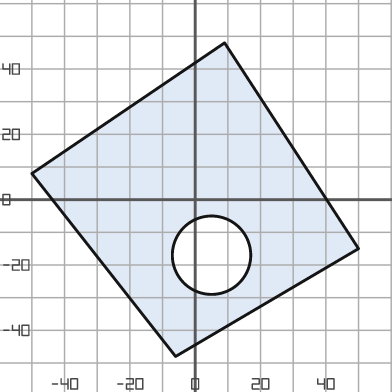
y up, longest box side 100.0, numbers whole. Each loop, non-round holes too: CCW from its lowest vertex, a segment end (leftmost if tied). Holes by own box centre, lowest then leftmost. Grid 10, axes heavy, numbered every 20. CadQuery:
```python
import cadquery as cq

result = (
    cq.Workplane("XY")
    .moveTo(-6.0, -48.0)
    .lineTo(50.0, -15.0)
    .lineTo(9.0, 48.0)
    .lineTo(-50.0, 8.0)
    .close()
    .moveTo(5.0, -17.0)
    .circle(12.0)
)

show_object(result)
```